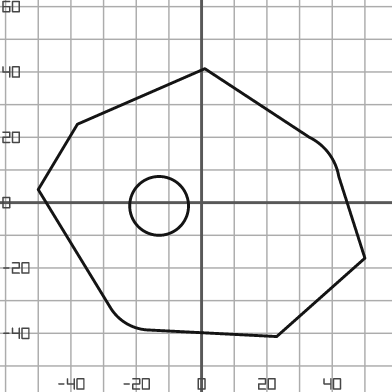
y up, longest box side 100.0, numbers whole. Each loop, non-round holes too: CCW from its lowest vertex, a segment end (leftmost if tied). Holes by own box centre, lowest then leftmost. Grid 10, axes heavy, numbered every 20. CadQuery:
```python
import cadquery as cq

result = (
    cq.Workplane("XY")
    .moveTo(23.0, -41.0)
    .lineTo(50.0, -17.0)
    .lineTo(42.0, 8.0)
    .threePointArc((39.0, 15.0), (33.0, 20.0))
    .lineTo(1.0, 41.0)
    .lineTo(-38.0, 24.0)
    .lineTo(-50.0, 4.0)
    .lineTo(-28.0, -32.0)
    .threePointArc((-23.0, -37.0), (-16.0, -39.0))
    .close()
    .moveTo(-13.0, -1.0)
    .circle(9.0)
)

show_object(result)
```